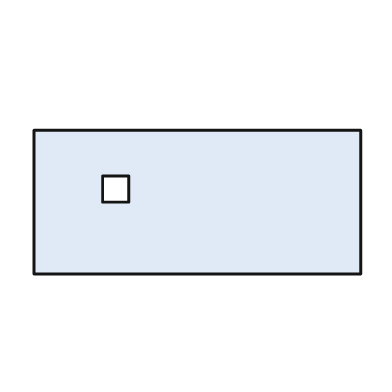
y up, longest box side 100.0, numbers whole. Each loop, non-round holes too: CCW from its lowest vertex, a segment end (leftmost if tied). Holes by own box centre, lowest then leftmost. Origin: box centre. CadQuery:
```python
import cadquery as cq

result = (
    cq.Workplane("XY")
    .moveTo(-50.0, -22.0)
    .lineTo(50.0, -22.0)
    .lineTo(50.0, 22.0)
    .lineTo(-50.0, 22.0)
    .close()
    .moveTo(-29.0, 0.0)
    .lineTo(-21.0, 0.0)
    .lineTo(-21.0, 8.0)
    .lineTo(-29.0, 8.0)
    .close()
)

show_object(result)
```